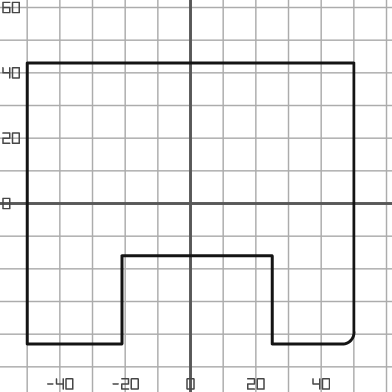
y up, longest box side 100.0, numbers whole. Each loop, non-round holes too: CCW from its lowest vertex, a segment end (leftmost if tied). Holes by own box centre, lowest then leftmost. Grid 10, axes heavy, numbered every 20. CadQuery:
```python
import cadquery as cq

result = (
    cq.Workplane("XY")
    .moveTo(-50.0, -43.0)
    .lineTo(-21.0, -43.0)
    .lineTo(-21.0, -16.0)
    .lineTo(25.0, -16.0)
    .lineTo(25.0, -43.0)
    .lineTo(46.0, -43.0)
    .threePointArc((49.0, -42.0), (50.0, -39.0))
    .lineTo(50.0, 43.0)
    .lineTo(-50.0, 43.0)
    .close()
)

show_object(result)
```